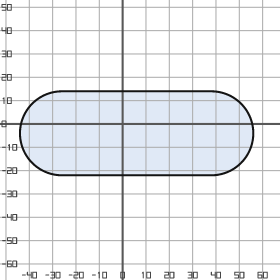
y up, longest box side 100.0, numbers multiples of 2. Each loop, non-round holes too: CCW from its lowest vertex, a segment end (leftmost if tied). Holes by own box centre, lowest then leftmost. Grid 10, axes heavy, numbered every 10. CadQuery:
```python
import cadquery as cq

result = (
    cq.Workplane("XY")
    .moveTo(-26.0, -22.0)
    .lineTo(38.0, -22.0)
    .threePointArc((56.0, -4.0), (38.0, 14.0))
    .lineTo(-26.0, 14.0)
    .threePointArc((-44.0, -4.0), (-26.0, -22.0))
    .close()
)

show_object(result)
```